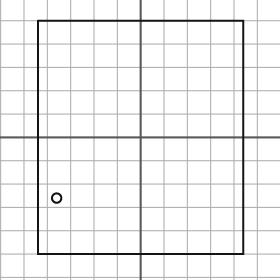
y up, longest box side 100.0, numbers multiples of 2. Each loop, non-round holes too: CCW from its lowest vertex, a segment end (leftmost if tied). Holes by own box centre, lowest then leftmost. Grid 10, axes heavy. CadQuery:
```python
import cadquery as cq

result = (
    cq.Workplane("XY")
    .moveTo(-44.0, -50.0)
    .lineTo(44.0, -50.0)
    .lineTo(44.0, 50.0)
    .lineTo(-44.0, 50.0)
    .close()
    .moveTo(-36.0, -26.0)
    .circle(2.0)
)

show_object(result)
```